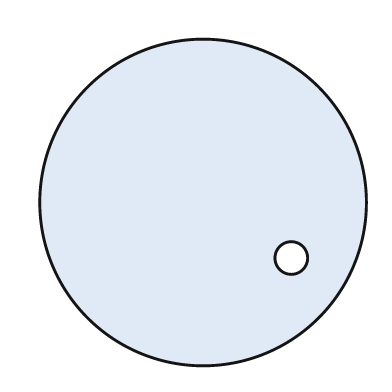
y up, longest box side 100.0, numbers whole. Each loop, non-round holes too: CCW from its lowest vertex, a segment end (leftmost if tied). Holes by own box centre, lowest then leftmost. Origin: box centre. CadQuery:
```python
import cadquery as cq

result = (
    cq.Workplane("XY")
    .moveTo(0.0, 0.0)
    .circle(50.0)
    .moveTo(27.0, -17.0)
    .circle(5.0)
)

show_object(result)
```